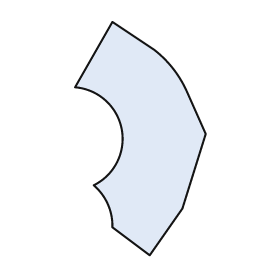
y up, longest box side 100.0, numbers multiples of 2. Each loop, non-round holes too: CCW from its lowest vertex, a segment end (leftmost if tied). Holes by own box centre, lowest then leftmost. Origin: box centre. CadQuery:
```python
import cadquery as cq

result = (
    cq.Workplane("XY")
    .moveTo(4.0, -50.0)
    .lineTo(18.0, -30.0)
    .lineTo(28.0, 2.0)
    .lineTo(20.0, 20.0)
    .threePointArc((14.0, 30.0), (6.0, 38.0))
    .lineTo(-12.0, 50.0)
    .lineTo(-28.0, 22.0)
    .threePointArc((-8.0, 4.0), (-20.0, -20.0))
    .threePointArc((-14.0, -28.0), (-12.0, -38.0))
    .close()
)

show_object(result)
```